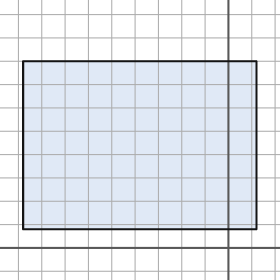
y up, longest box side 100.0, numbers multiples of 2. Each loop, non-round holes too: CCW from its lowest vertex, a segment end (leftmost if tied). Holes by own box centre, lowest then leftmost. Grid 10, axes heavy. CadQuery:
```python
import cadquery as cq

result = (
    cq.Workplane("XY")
    .moveTo(-88.0, 8.0)
    .lineTo(12.0, 8.0)
    .lineTo(12.0, 80.0)
    .lineTo(-88.0, 80.0)
    .close()
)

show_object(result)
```